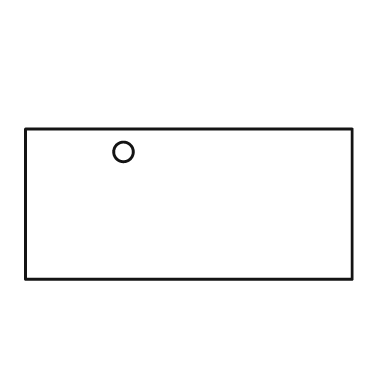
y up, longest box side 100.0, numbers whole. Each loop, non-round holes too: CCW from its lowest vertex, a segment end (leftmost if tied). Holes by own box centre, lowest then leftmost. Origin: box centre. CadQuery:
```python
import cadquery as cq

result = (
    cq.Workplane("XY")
    .moveTo(-50.0, -23.0)
    .lineTo(50.0, -23.0)
    .lineTo(50.0, 23.0)
    .lineTo(-50.0, 23.0)
    .close()
    .moveTo(-20.0, 16.0)
    .circle(3.0)
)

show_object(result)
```